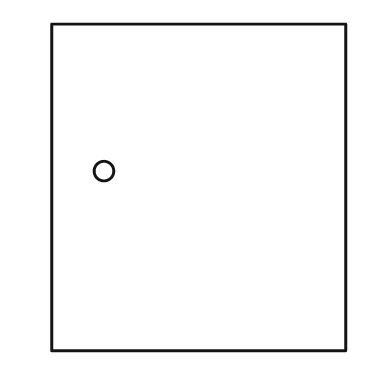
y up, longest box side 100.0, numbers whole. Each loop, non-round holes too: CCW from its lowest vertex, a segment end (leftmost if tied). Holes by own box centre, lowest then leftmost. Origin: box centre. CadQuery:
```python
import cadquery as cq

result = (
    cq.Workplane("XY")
    .moveTo(-45.0, -50.0)
    .lineTo(45.0, -50.0)
    .lineTo(45.0, 50.0)
    .lineTo(-45.0, 50.0)
    .close()
    .moveTo(-29.0, 5.0)
    .circle(3.0)
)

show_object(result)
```